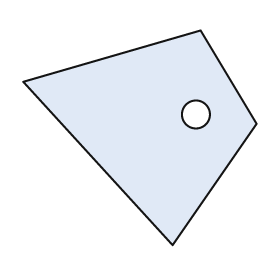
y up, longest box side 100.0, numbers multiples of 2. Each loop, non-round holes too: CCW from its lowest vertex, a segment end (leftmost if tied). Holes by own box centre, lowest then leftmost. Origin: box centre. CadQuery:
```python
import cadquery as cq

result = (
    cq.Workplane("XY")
    .moveTo(14.0, -46.0)
    .lineTo(50.0, 6.0)
    .lineTo(26.0, 46.0)
    .lineTo(-50.0, 24.0)
    .close()
    .moveTo(24.0, 10.0)
    .circle(6.0)
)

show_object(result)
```